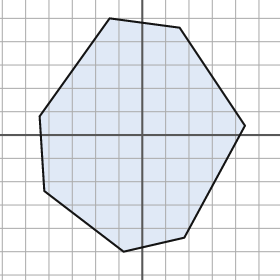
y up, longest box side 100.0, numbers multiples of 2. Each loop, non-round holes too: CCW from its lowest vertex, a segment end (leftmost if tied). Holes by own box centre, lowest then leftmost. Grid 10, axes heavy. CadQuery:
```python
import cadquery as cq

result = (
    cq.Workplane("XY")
    .moveTo(-8.0, -50.0)
    .lineTo(18.0, -44.0)
    .lineTo(44.0, 4.0)
    .lineTo(16.0, 46.0)
    .lineTo(-14.0, 50.0)
    .lineTo(-44.0, 8.0)
    .lineTo(-42.0, -24.0)
    .close()
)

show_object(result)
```